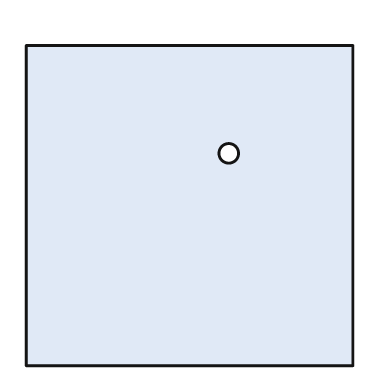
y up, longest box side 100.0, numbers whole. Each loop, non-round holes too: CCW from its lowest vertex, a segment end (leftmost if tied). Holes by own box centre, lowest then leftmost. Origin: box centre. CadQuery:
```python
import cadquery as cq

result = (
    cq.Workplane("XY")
    .moveTo(-50.0, -49.0)
    .lineTo(50.0, -49.0)
    .lineTo(50.0, 49.0)
    .lineTo(-50.0, 49.0)
    .close()
    .moveTo(12.0, 16.0)
    .circle(3.0)
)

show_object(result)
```